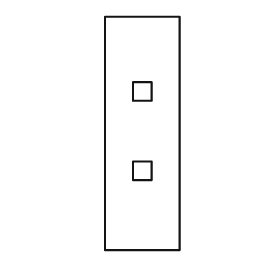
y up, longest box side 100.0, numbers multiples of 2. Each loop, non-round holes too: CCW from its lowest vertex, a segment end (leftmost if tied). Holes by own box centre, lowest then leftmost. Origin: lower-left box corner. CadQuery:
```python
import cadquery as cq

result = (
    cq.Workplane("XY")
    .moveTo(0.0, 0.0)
    .lineTo(32.0, 0.0)
    .lineTo(32.0, 100.0)
    .lineTo(0.0, 100.0)
    .close()
    .moveTo(12.0, 30.0)
    .lineTo(20.0, 30.0)
    .lineTo(20.0, 38.0)
    .lineTo(12.0, 38.0)
    .close()
    .moveTo(12.0, 64.0)
    .lineTo(20.0, 64.0)
    .lineTo(20.0, 72.0)
    .lineTo(12.0, 72.0)
    .close()
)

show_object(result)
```